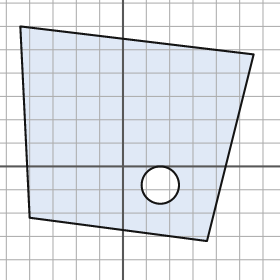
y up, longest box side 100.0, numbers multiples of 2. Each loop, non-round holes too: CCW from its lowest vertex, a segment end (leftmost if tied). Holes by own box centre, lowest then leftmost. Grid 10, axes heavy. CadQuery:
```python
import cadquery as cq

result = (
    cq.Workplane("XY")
    .moveTo(36.0, -32.0)
    .lineTo(56.0, 48.0)
    .lineTo(-44.0, 60.0)
    .lineTo(-40.0, -22.0)
    .close()
    .moveTo(16.0, -8.0)
    .circle(8.0)
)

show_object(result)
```